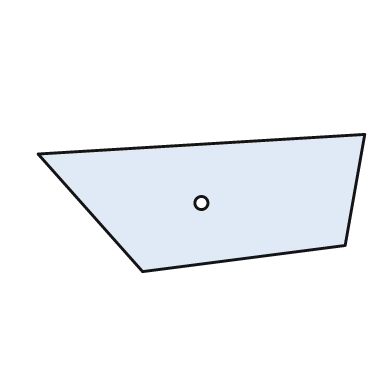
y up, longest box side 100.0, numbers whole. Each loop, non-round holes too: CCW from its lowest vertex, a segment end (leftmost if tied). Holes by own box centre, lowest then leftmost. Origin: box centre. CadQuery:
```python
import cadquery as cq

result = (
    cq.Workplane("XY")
    .moveTo(-18.0, -21.0)
    .lineTo(44.0, -13.0)
    .lineTo(50.0, 21.0)
    .lineTo(-50.0, 15.0)
    .close()
    .moveTo(0.0, 0.0)
    .circle(2.0)
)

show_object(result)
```